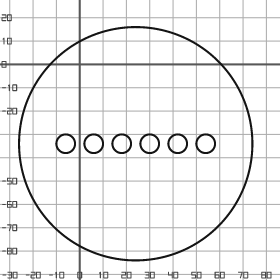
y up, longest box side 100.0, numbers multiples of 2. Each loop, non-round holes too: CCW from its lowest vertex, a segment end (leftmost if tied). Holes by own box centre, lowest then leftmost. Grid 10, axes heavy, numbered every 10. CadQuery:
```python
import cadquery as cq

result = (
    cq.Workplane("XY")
    .moveTo(24.0, -34.0)
    .circle(50.0)
    .moveTo(-6.0, -34.0)
    .circle(4.0)
    .moveTo(6.0, -34.0)
    .circle(4.0)
    .moveTo(18.0, -34.0)
    .circle(4.0)
    .moveTo(30.0, -34.0)
    .circle(4.0)
    .moveTo(42.0, -34.0)
    .circle(4.0)
    .moveTo(54.0, -34.0)
    .circle(4.0)
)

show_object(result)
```